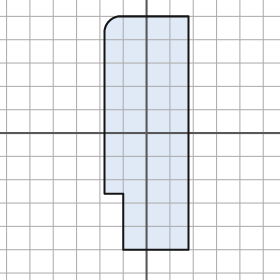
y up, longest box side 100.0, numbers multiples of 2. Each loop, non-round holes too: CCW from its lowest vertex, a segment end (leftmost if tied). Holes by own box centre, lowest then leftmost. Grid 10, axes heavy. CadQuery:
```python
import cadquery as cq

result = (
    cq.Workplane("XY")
    .moveTo(-10.0, -50.0)
    .lineTo(18.0, -50.0)
    .lineTo(18.0, 50.0)
    .lineTo(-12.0, 50.0)
    .threePointArc((-16.0, 48.0), (-18.0, 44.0))
    .lineTo(-18.0, -26.0)
    .lineTo(-10.0, -26.0)
    .close()
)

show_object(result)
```